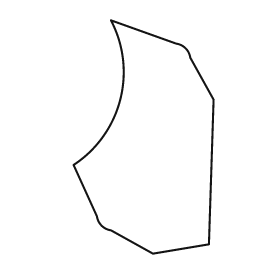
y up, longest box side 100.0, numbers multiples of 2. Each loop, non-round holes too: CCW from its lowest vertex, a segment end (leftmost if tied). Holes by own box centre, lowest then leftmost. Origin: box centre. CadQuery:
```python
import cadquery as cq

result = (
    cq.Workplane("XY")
    .moveTo(4.0, -50.0)
    .lineTo(28.0, -46.0)
    .lineTo(30.0, 16.0)
    .lineTo(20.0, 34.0)
    .threePointArc((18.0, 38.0), (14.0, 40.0))
    .lineTo(-14.0, 50.0)
    .threePointArc((-10.0, 16.0), (-30.0, -12.0))
    .lineTo(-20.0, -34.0)
    .threePointArc((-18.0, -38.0), (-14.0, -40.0))
    .close()
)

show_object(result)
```